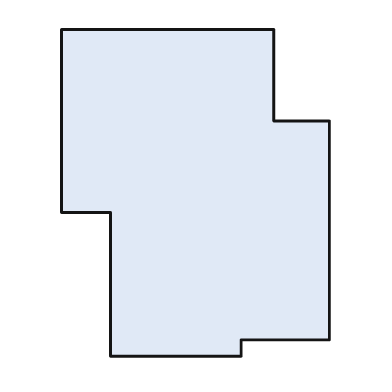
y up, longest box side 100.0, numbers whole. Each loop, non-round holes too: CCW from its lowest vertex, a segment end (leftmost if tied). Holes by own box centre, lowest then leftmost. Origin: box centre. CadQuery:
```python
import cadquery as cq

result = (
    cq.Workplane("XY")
    .moveTo(-26.0, -50.0)
    .lineTo(14.0, -50.0)
    .lineTo(14.0, -45.0)
    .lineTo(41.0, -45.0)
    .lineTo(41.0, 22.0)
    .lineTo(24.0, 22.0)
    .lineTo(24.0, 50.0)
    .lineTo(-41.0, 50.0)
    .lineTo(-41.0, -6.0)
    .lineTo(-26.0, -6.0)
    .close()
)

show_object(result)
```